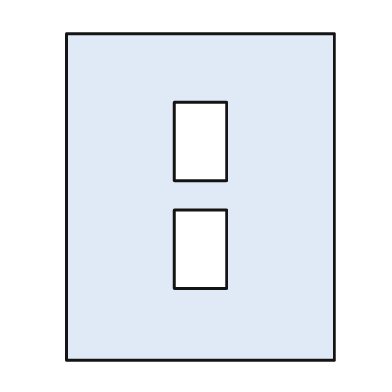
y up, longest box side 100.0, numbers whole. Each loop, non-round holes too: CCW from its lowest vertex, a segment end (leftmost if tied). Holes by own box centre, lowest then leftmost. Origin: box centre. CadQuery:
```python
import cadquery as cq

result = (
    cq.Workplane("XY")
    .moveTo(-41.0, -50.0)
    .lineTo(41.0, -50.0)
    .lineTo(41.0, 50.0)
    .lineTo(-41.0, 50.0)
    .close()
    .moveTo(-8.0, -28.0)
    .lineTo(8.0, -28.0)
    .lineTo(8.0, -4.0)
    .lineTo(-8.0, -4.0)
    .close()
    .moveTo(-8.0, 5.0)
    .lineTo(8.0, 5.0)
    .lineTo(8.0, 29.0)
    .lineTo(-8.0, 29.0)
    .close()
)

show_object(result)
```